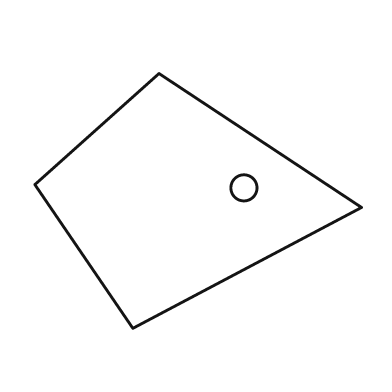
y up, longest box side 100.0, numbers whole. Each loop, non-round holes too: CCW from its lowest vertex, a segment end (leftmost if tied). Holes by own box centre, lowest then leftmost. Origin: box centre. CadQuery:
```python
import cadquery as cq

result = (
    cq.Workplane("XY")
    .moveTo(-20.0, -39.0)
    .lineTo(50.0, -2.0)
    .lineTo(-12.0, 39.0)
    .lineTo(-50.0, 5.0)
    .close()
    .moveTo(14.0, 4.0)
    .circle(4.0)
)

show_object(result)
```